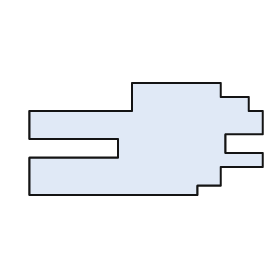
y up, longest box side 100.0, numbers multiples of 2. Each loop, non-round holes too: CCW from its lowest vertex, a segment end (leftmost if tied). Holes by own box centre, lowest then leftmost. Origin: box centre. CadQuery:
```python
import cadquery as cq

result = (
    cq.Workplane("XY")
    .moveTo(-50.0, -24.0)
    .lineTo(22.0, -24.0)
    .lineTo(22.0, -20.0)
    .lineTo(32.0, -20.0)
    .lineTo(32.0, -12.0)
    .lineTo(50.0, -12.0)
    .lineTo(50.0, -6.0)
    .lineTo(34.0, -6.0)
    .lineTo(34.0, 2.0)
    .lineTo(50.0, 2.0)
    .lineTo(50.0, 12.0)
    .lineTo(44.0, 12.0)
    .lineTo(44.0, 18.0)
    .lineTo(32.0, 18.0)
    .lineTo(32.0, 24.0)
    .lineTo(-6.0, 24.0)
    .lineTo(-6.0, 12.0)
    .lineTo(-50.0, 12.0)
    .lineTo(-50.0, 0.0)
    .lineTo(-12.0, 0.0)
    .lineTo(-12.0, -8.0)
    .lineTo(-50.0, -8.0)
    .close()
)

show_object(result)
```